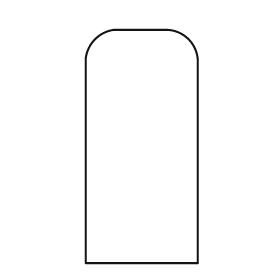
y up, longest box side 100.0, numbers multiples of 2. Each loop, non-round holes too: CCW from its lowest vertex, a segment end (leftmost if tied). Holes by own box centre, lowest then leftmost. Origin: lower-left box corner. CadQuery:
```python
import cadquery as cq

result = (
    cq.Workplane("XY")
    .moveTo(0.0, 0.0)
    .lineTo(48.0, 0.0)
    .lineTo(48.0, 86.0)
    .threePointArc((44.0, 96.0), (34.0, 100.0))
    .lineTo(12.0, 100.0)
    .threePointArc((4.0, 96.0), (0.0, 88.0))
    .close()
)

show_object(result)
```